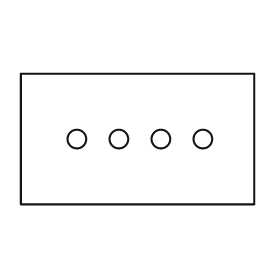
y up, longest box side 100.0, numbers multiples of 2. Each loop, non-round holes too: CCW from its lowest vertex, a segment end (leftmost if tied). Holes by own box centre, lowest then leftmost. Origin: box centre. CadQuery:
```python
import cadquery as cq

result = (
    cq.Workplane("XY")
    .moveTo(-50.0, -28.0)
    .lineTo(50.0, -28.0)
    .lineTo(50.0, 28.0)
    .lineTo(-50.0, 28.0)
    .close()
    .moveTo(-26.0, 0.0)
    .circle(4.0)
    .moveTo(-8.0, 0.0)
    .circle(4.0)
    .moveTo(10.0, 0.0)
    .circle(4.0)
    .moveTo(28.0, 0.0)
    .circle(4.0)
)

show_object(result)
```